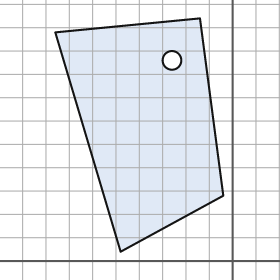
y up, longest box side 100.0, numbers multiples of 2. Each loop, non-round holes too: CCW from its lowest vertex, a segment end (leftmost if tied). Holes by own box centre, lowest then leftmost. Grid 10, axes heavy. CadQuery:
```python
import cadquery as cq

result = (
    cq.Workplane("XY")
    .moveTo(-48.0, 4.0)
    .lineTo(-4.0, 28.0)
    .lineTo(-14.0, 104.0)
    .lineTo(-76.0, 98.0)
    .close()
    .moveTo(-26.0, 86.0)
    .circle(4.0)
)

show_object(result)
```